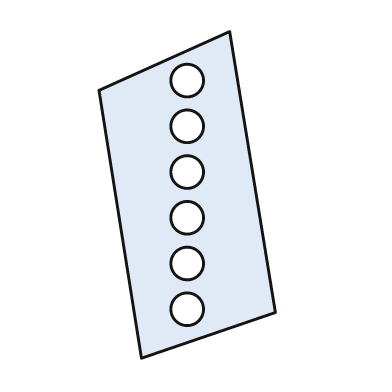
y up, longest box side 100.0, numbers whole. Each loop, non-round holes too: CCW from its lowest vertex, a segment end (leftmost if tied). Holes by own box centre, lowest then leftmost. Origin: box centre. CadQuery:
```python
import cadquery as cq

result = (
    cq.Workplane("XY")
    .moveTo(-14.0, -50.0)
    .lineTo(27.0, -36.0)
    .lineTo(13.0, 50.0)
    .lineTo(-27.0, 32.0)
    .close()
    .moveTo(0.0, -35.0)
    .circle(5.0)
    .moveTo(0.0, -21.0)
    .circle(5.0)
    .moveTo(0.0, -7.0)
    .circle(5.0)
    .moveTo(0.0, 7.0)
    .circle(5.0)
    .moveTo(0.0, 21.0)
    .circle(5.0)
    .moveTo(0.0, 35.0)
    .circle(5.0)
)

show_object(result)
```